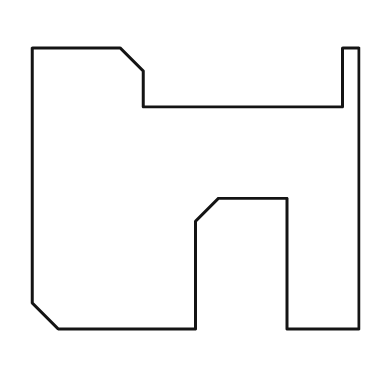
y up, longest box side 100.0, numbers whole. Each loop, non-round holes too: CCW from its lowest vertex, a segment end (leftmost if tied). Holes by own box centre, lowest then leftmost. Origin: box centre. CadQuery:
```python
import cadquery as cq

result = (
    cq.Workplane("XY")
    .moveTo(-42.0, -43.0)
    .lineTo(0.0, -43.0)
    .lineTo(0.0, -10.0)
    .lineTo(7.0, -3.0)
    .lineTo(28.0, -3.0)
    .lineTo(28.0, -43.0)
    .lineTo(50.0, -43.0)
    .lineTo(50.0, 43.0)
    .lineTo(45.0, 43.0)
    .lineTo(45.0, 25.0)
    .lineTo(-16.0, 25.0)
    .lineTo(-16.0, 36.0)
    .lineTo(-23.0, 43.0)
    .lineTo(-50.0, 43.0)
    .lineTo(-50.0, -35.0)
    .close()
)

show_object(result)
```